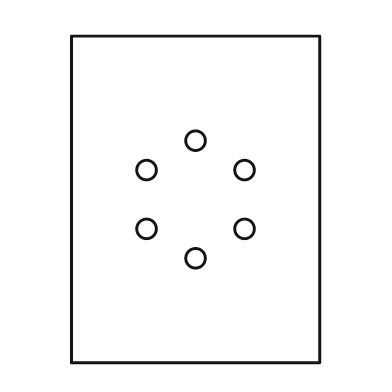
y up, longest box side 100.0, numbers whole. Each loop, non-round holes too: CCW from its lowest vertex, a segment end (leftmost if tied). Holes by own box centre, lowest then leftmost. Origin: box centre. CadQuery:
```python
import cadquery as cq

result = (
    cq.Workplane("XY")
    .moveTo(-38.0, -50.0)
    .lineTo(38.0, -50.0)
    .lineTo(38.0, 50.0)
    .lineTo(-38.0, 50.0)
    .close()
    .moveTo(0.0, -18.0)
    .circle(3.0)
    .moveTo(-15.0, -9.0)
    .circle(3.0)
    .moveTo(15.0, -9.0)
    .circle(3.0)
    .moveTo(-15.0, 9.0)
    .circle(3.0)
    .moveTo(15.0, 9.0)
    .circle(3.0)
    .moveTo(0.0, 18.0)
    .circle(3.0)
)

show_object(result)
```